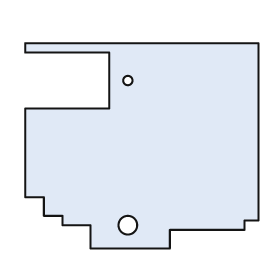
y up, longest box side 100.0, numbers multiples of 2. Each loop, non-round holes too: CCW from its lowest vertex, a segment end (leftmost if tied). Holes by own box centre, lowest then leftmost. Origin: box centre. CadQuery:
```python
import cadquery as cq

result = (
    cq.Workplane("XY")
    .moveTo(-22.0, -44.0)
    .lineTo(12.0, -44.0)
    .lineTo(12.0, -36.0)
    .lineTo(44.0, -36.0)
    .lineTo(44.0, -32.0)
    .lineTo(50.0, -32.0)
    .lineTo(50.0, 44.0)
    .lineTo(-50.0, 44.0)
    .lineTo(-50.0, 40.0)
    .lineTo(-14.0, 40.0)
    .lineTo(-14.0, 16.0)
    .lineTo(-50.0, 16.0)
    .lineTo(-50.0, -22.0)
    .lineTo(-42.0, -22.0)
    .lineTo(-42.0, -30.0)
    .lineTo(-34.0, -30.0)
    .lineTo(-34.0, -34.0)
    .lineTo(-22.0, -34.0)
    .close()
    .moveTo(-6.0, -34.0)
    .circle(4.0)
    .moveTo(-6.0, 28.0)
    .circle(2.0)
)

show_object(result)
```